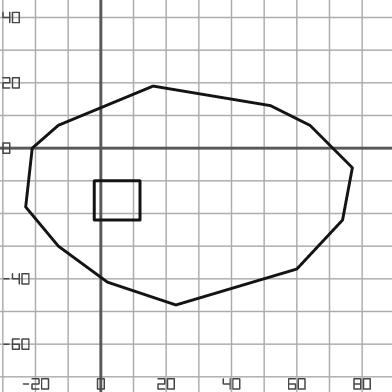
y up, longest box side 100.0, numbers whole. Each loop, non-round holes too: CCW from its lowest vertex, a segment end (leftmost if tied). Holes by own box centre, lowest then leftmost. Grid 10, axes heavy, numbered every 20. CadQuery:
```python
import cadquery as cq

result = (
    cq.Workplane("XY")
    .moveTo(23.0, -48.0)
    .lineTo(60.0, -37.0)
    .lineTo(74.0, -22.0)
    .lineTo(77.0, -6.0)
    .lineTo(64.0, 7.0)
    .lineTo(52.0, 13.0)
    .lineTo(16.0, 19.0)
    .lineTo(-13.0, 7.0)
    .lineTo(-21.0, 0.0)
    .lineTo(-23.0, -18.0)
    .lineTo(-13.0, -30.0)
    .lineTo(2.0, -41.0)
    .close()
    .moveTo(-2.0, -22.0)
    .lineTo(12.0, -22.0)
    .lineTo(12.0, -10.0)
    .lineTo(-2.0, -10.0)
    .close()
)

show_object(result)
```